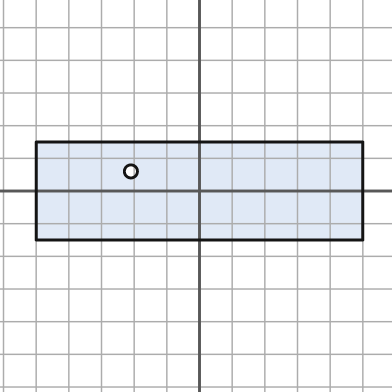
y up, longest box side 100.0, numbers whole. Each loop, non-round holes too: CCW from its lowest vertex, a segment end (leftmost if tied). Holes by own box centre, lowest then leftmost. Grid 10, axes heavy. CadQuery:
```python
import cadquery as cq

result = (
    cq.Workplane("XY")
    .moveTo(-50.0, -15.0)
    .lineTo(50.0, -15.0)
    .lineTo(50.0, 15.0)
    .lineTo(-50.0, 15.0)
    .close()
    .moveTo(-21.0, 6.0)
    .circle(2.0)
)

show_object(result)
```